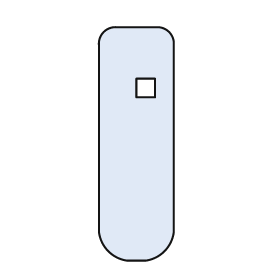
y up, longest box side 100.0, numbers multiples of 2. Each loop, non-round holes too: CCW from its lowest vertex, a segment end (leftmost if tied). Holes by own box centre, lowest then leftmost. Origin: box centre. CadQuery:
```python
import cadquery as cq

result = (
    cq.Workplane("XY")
    .moveTo(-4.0, -50.0)
    .lineTo(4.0, -50.0)
    .threePointArc((12.0, -46.0), (16.0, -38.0))
    .lineTo(16.0, 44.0)
    .threePointArc((14.0, 48.0), (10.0, 50.0))
    .lineTo(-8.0, 50.0)
    .threePointArc((-14.0, 48.0), (-16.0, 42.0))
    .lineTo(-16.0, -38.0)
    .threePointArc((-12.0, -46.0), (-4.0, -50.0))
    .close()
    .moveTo(0.0, 20.0)
    .lineTo(8.0, 20.0)
    .lineTo(8.0, 28.0)
    .lineTo(0.0, 28.0)
    .close()
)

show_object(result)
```